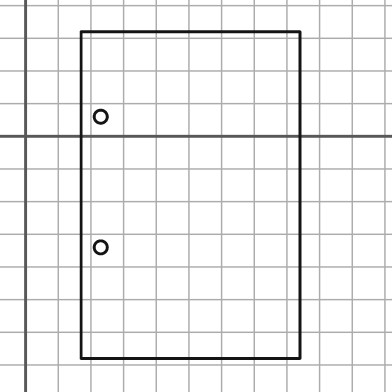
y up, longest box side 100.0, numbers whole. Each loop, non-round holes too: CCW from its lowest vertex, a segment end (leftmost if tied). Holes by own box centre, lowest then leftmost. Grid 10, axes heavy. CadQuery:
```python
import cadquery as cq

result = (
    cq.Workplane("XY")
    .moveTo(17.0, -68.0)
    .lineTo(84.0, -68.0)
    .lineTo(84.0, 32.0)
    .lineTo(17.0, 32.0)
    .close()
    .moveTo(23.0, -34.0)
    .circle(2.0)
    .moveTo(23.0, 6.0)
    .circle(2.0)
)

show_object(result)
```